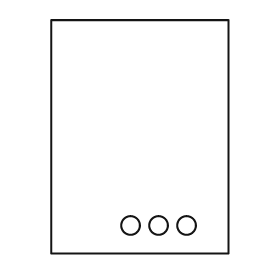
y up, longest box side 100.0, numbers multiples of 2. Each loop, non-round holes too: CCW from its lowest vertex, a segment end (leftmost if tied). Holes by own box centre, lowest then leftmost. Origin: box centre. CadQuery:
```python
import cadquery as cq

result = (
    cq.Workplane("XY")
    .moveTo(-38.0, -50.0)
    .lineTo(38.0, -50.0)
    .lineTo(38.0, 50.0)
    .lineTo(-38.0, 50.0)
    .close()
    .moveTo(-4.0, -38.0)
    .circle(4.0)
    .moveTo(8.0, -38.0)
    .circle(4.0)
    .moveTo(20.0, -38.0)
    .circle(4.0)
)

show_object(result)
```